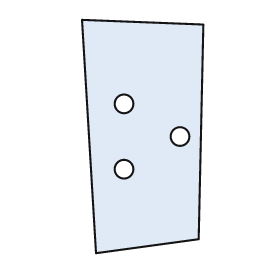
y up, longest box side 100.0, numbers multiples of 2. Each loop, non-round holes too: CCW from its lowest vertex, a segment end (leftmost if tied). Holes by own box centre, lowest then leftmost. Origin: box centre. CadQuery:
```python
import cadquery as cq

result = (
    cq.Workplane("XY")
    .moveTo(-20.0, -50.0)
    .lineTo(24.0, -44.0)
    .lineTo(26.0, 48.0)
    .lineTo(-26.0, 50.0)
    .close()
    .moveTo(-8.0, -14.0)
    .circle(4.0)
    .moveTo(16.0, 0.0)
    .circle(4.0)
    .moveTo(-8.0, 14.0)
    .circle(4.0)
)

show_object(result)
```